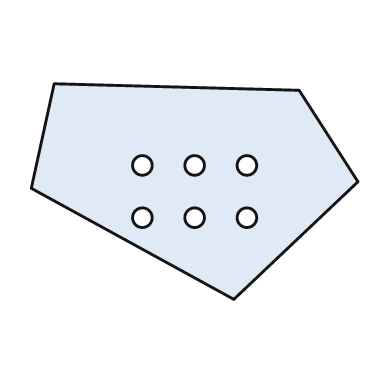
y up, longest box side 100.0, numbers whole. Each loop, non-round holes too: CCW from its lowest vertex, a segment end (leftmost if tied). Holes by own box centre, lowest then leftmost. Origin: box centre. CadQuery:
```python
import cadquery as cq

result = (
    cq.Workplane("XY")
    .moveTo(12.0, -33.0)
    .lineTo(50.0, 3.0)
    .lineTo(32.0, 31.0)
    .lineTo(-43.0, 33.0)
    .lineTo(-50.0, 1.0)
    .close()
    .moveTo(-16.0, -8.0)
    .circle(3.0)
    .moveTo(0.0, -8.0)
    .circle(3.0)
    .moveTo(16.0, -8.0)
    .circle(3.0)
    .moveTo(-16.0, 8.0)
    .circle(3.0)
    .moveTo(0.0, 8.0)
    .circle(3.0)
    .moveTo(16.0, 8.0)
    .circle(3.0)
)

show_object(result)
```